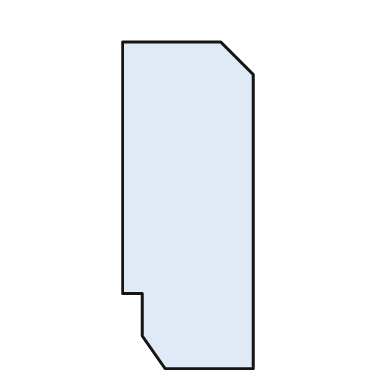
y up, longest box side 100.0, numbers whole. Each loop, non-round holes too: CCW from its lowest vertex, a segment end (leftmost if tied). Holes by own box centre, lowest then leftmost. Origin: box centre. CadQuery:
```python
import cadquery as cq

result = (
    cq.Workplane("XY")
    .moveTo(-7.0, -50.0)
    .lineTo(20.0, -50.0)
    .lineTo(20.0, 40.0)
    .lineTo(10.0, 50.0)
    .lineTo(-20.0, 50.0)
    .lineTo(-20.0, -27.0)
    .lineTo(-14.0, -27.0)
    .lineTo(-14.0, -40.0)
    .close()
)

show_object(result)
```